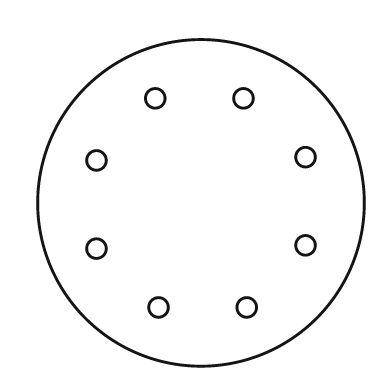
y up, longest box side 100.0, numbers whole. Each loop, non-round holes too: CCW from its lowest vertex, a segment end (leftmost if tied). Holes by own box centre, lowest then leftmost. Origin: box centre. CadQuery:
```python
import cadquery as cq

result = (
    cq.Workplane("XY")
    .moveTo(0.0, 0.0)
    .circle(50.0)
    .moveTo(-13.0, -32.0)
    .circle(3.0)
    .moveTo(14.0, -32.0)
    .circle(3.0)
    .moveTo(-32.0, -14.0)
    .circle(3.0)
    .moveTo(32.0, -13.0)
    .circle(3.0)
    .moveTo(-32.0, 13.0)
    .circle(3.0)
    .moveTo(32.0, 14.0)
    .circle(3.0)
    .moveTo(-14.0, 32.0)
    .circle(3.0)
    .moveTo(13.0, 32.0)
    .circle(3.0)
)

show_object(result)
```